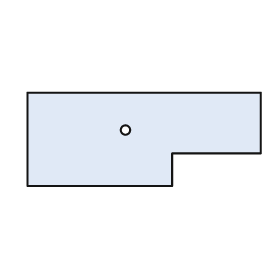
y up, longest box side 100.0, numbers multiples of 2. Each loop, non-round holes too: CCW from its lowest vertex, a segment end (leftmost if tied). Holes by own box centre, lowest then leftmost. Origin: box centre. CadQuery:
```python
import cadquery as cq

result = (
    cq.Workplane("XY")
    .moveTo(-50.0, -20.0)
    .lineTo(12.0, -20.0)
    .lineTo(12.0, -6.0)
    .lineTo(50.0, -6.0)
    .lineTo(50.0, 20.0)
    .lineTo(-50.0, 20.0)
    .close()
    .moveTo(-8.0, 4.0)
    .circle(2.0)
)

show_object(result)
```